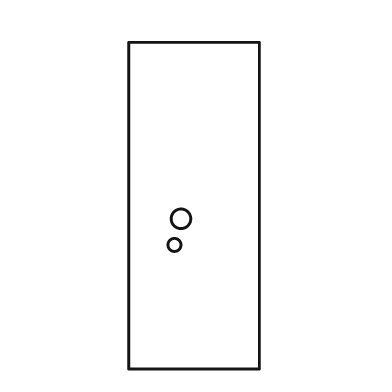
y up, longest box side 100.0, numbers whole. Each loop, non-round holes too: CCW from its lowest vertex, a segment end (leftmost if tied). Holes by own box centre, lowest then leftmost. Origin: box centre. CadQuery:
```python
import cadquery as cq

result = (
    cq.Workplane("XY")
    .moveTo(-20.0, -50.0)
    .lineTo(20.0, -50.0)
    .lineTo(20.0, 50.0)
    .lineTo(-20.0, 50.0)
    .close()
    .moveTo(-6.0, -12.0)
    .circle(2.0)
    .moveTo(-4.0, -4.0)
    .circle(3.0)
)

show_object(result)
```